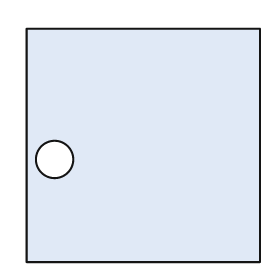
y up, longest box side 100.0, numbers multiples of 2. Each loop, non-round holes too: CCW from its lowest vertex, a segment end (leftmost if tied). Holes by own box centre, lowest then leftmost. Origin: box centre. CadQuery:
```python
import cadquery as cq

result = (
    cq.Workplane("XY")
    .moveTo(-50.0, -50.0)
    .lineTo(50.0, -50.0)
    .lineTo(50.0, 50.0)
    .lineTo(-50.0, 50.0)
    .close()
    .moveTo(-38.0, -6.0)
    .circle(8.0)
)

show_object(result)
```